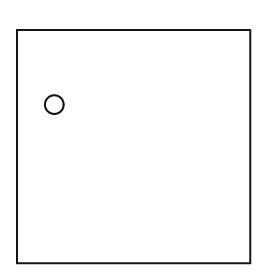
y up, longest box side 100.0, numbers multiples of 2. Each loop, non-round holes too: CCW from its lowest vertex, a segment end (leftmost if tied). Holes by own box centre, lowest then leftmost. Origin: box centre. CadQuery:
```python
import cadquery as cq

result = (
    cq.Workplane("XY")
    .moveTo(-50.0, -50.0)
    .lineTo(50.0, -50.0)
    .lineTo(50.0, 50.0)
    .lineTo(-50.0, 50.0)
    .close()
    .moveTo(-34.0, 18.0)
    .circle(4.0)
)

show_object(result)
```